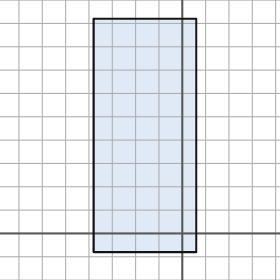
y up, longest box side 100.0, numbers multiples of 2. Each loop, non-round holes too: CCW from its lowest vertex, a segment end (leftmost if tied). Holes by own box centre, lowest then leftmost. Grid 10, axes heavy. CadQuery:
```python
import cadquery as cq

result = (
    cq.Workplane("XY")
    .moveTo(-38.0, -8.0)
    .lineTo(6.0, -8.0)
    .lineTo(6.0, 92.0)
    .lineTo(-38.0, 92.0)
    .close()
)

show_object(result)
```